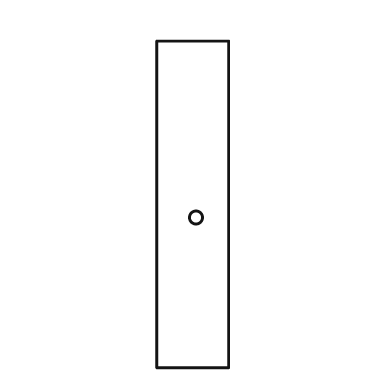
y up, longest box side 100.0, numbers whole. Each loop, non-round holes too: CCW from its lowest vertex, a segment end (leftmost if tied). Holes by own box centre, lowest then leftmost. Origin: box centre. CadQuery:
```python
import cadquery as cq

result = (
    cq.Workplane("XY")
    .moveTo(-11.0, -50.0)
    .lineTo(11.0, -50.0)
    .lineTo(11.0, 50.0)
    .lineTo(-11.0, 50.0)
    .close()
    .moveTo(1.0, -4.0)
    .circle(2.0)
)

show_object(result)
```